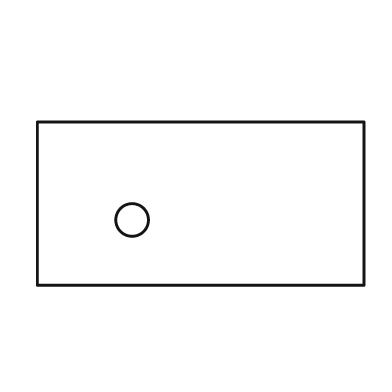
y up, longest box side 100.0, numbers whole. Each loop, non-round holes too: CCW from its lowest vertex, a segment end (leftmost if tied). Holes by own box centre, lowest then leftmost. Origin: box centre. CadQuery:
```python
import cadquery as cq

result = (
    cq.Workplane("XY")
    .moveTo(-50.0, -25.0)
    .lineTo(50.0, -25.0)
    .lineTo(50.0, 25.0)
    .lineTo(-50.0, 25.0)
    .close()
    .moveTo(-21.0, -5.0)
    .circle(5.0)
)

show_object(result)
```